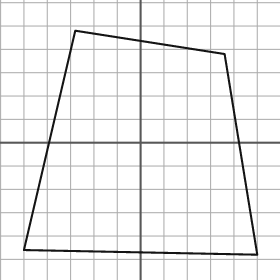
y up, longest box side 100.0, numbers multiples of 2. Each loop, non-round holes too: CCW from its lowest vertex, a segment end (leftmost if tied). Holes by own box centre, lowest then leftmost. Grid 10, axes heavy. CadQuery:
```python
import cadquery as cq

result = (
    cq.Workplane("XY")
    .moveTo(50.0, -48.0)
    .lineTo(36.0, 38.0)
    .lineTo(-28.0, 48.0)
    .lineTo(-50.0, -46.0)
    .close()
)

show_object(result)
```